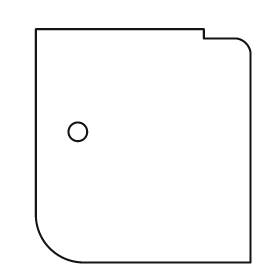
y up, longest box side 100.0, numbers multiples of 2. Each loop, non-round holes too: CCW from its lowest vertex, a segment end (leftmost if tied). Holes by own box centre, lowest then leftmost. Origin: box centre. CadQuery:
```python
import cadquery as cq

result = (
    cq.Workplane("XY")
    .moveTo(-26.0, -50.0)
    .lineTo(46.0, -50.0)
    .lineTo(46.0, 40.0)
    .threePointArc((44.0, 44.0), (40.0, 46.0))
    .lineTo(26.0, 46.0)
    .lineTo(26.0, 50.0)
    .lineTo(-46.0, 50.0)
    .lineTo(-46.0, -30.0)
    .threePointArc((-40.0, -44.0), (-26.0, -50.0))
    .close()
    .moveTo(-28.0, 6.0)
    .circle(4.0)
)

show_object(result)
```